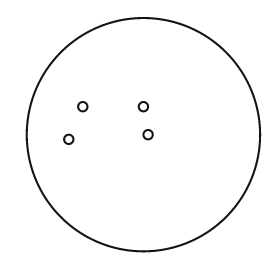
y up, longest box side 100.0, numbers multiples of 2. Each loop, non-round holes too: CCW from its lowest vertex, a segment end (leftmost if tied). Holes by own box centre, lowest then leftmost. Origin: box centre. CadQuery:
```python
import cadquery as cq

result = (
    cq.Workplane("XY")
    .moveTo(0.0, 0.0)
    .circle(50.0)
    .moveTo(-32.0, -2.0)
    .circle(2.0)
    .moveTo(2.0, 0.0)
    .circle(2.0)
    .moveTo(-26.0, 12.0)
    .circle(2.0)
    .moveTo(0.0, 12.0)
    .circle(2.0)
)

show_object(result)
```